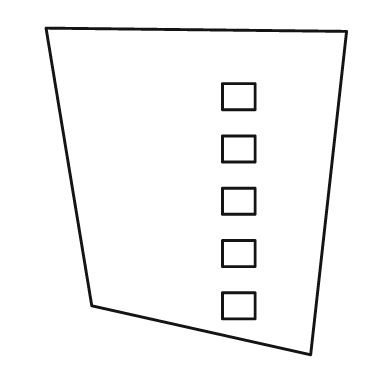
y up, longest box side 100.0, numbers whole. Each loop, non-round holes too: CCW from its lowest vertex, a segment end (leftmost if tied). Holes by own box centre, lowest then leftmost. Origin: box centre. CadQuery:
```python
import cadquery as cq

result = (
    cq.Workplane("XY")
    .moveTo(35.0, -50.0)
    .lineTo(46.0, 49.0)
    .lineTo(-46.0, 50.0)
    .lineTo(-32.0, -35.0)
    .close()
    .moveTo(8.0, -39.0)
    .lineTo(18.0, -39.0)
    .lineTo(18.0, -31.0)
    .lineTo(8.0, -31.0)
    .close()
    .moveTo(8.0, -23.0)
    .lineTo(18.0, -23.0)
    .lineTo(18.0, -15.0)
    .lineTo(8.0, -15.0)
    .close()
    .moveTo(8.0, -7.0)
    .lineTo(18.0, -7.0)
    .lineTo(18.0, 1.0)
    .lineTo(8.0, 1.0)
    .close()
    .moveTo(8.0, 9.0)
    .lineTo(18.0, 9.0)
    .lineTo(18.0, 17.0)
    .lineTo(8.0, 17.0)
    .close()
    .moveTo(8.0, 25.0)
    .lineTo(18.0, 25.0)
    .lineTo(18.0, 33.0)
    .lineTo(8.0, 33.0)
    .close()
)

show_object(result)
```